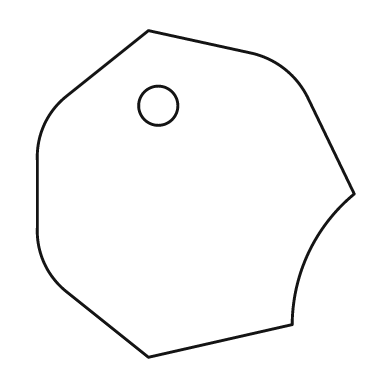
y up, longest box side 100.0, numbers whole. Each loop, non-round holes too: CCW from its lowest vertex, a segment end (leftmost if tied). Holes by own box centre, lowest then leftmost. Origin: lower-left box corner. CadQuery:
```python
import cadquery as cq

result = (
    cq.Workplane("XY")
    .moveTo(34.0, 0.0)
    .lineTo(78.0, 10.0)
    .threePointArc((83.0, 32.0), (97.0, 50.0))
    .lineTo(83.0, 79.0)
    .threePointArc((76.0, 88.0), (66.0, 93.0))
    .lineTo(34.0, 100.0)
    .lineTo(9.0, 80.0)
    .threePointArc((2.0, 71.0), (0.0, 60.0))
    .lineTo(0.0, 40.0)
    .threePointArc((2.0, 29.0), (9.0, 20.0))
    .close()
    .moveTo(37.0, 77.0)
    .circle(6.0)
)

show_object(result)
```